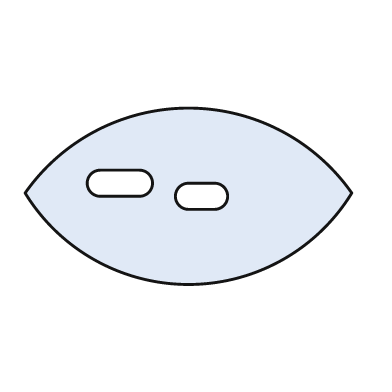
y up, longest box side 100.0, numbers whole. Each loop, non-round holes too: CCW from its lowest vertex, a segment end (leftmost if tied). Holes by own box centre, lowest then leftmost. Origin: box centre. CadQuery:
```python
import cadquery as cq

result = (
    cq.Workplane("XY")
    .moveTo(-50.0, 1.0)
    .threePointArc((0.0, -27.0), (50.0, 1.0))
    .threePointArc((0.0, 27.0), (-50.0, 1.0))
    .close()
    .moveTo(0.0, -4.0)
    .lineTo(8.0, -4.0)
    .threePointArc((12.0, 0.0), (8.0, 4.0))
    .lineTo(0.0, 4.0)
    .threePointArc((-4.0, 0.0), (0.0, -4.0))
    .close()
    .moveTo(-27.0, 0.0)
    .lineTo(-15.0, 0.0)
    .threePointArc((-11.0, 4.0), (-15.0, 8.0))
    .lineTo(-27.0, 8.0)
    .threePointArc((-31.0, 4.0), (-27.0, 0.0))
    .close()
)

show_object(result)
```